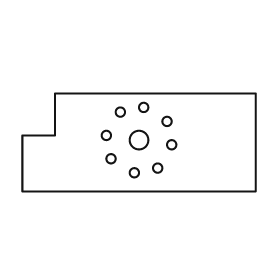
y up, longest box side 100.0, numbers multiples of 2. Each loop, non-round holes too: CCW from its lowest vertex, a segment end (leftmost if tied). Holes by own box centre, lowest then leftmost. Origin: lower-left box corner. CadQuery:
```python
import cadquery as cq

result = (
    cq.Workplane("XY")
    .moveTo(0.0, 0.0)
    .lineTo(100.0, 0.0)
    .lineTo(100.0, 42.0)
    .lineTo(14.0, 42.0)
    .lineTo(14.0, 24.0)
    .lineTo(0.0, 24.0)
    .close()
    .moveTo(48.0, 8.0)
    .circle(2.0)
    .moveTo(58.0, 10.0)
    .circle(2.0)
    .moveTo(38.0, 14.0)
    .circle(2.0)
    .moveTo(64.0, 20.0)
    .circle(2.0)
    .moveTo(50.0, 22.0)
    .circle(4.0)
    .moveTo(36.0, 24.0)
    .circle(2.0)
    .moveTo(62.0, 30.0)
    .circle(2.0)
    .moveTo(42.0, 34.0)
    .circle(2.0)
    .moveTo(52.0, 36.0)
    .circle(2.0)
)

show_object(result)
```